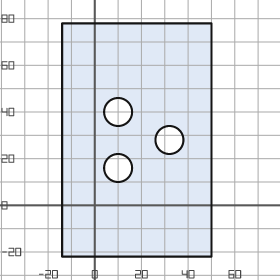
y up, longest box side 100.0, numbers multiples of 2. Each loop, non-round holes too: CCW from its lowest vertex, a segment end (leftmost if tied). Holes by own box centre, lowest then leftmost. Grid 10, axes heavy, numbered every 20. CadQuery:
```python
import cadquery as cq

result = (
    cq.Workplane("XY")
    .moveTo(-14.0, -22.0)
    .lineTo(50.0, -22.0)
    .lineTo(50.0, 78.0)
    .lineTo(-14.0, 78.0)
    .close()
    .moveTo(10.0, 16.0)
    .circle(6.0)
    .moveTo(32.0, 28.0)
    .circle(6.0)
    .moveTo(10.0, 40.0)
    .circle(6.0)
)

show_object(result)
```